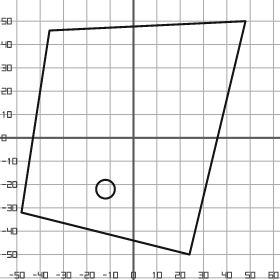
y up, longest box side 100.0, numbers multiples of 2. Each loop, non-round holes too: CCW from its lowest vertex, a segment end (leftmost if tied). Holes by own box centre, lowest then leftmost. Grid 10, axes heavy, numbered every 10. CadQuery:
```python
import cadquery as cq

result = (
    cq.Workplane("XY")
    .moveTo(24.0, -50.0)
    .lineTo(48.0, 50.0)
    .lineTo(-36.0, 46.0)
    .lineTo(-48.0, -32.0)
    .close()
    .moveTo(-12.0, -22.0)
    .circle(4.0)
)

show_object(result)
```